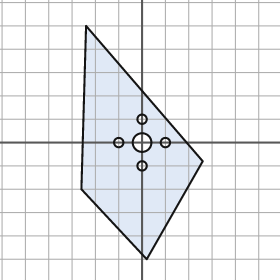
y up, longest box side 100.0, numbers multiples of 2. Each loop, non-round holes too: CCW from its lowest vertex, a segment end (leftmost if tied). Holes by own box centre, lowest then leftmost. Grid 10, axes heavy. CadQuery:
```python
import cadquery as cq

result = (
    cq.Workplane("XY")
    .moveTo(2.0, -50.0)
    .lineTo(26.0, -8.0)
    .lineTo(-24.0, 50.0)
    .lineTo(-26.0, -20.0)
    .close()
    .moveTo(0.0, -10.0)
    .circle(2.0)
    .moveTo(-10.0, 0.0)
    .circle(2.0)
    .moveTo(0.0, 0.0)
    .circle(4.0)
    .moveTo(10.0, 0.0)
    .circle(2.0)
    .moveTo(0.0, 10.0)
    .circle(2.0)
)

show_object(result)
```